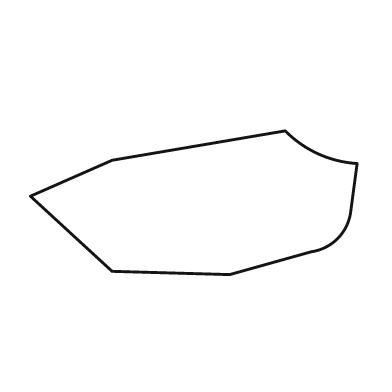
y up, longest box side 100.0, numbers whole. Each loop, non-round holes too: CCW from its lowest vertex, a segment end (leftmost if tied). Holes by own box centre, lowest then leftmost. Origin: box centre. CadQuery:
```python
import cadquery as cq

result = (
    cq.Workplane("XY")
    .moveTo(11.0, -22.0)
    .lineTo(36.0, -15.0)
    .threePointArc((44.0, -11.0), (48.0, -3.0))
    .lineTo(50.0, 12.0)
    .threePointArc((38.0, 15.0), (28.0, 22.0))
    .lineTo(-25.0, 13.0)
    .lineTo(-50.0, 2.0)
    .lineTo(-25.0, -21.0)
    .close()
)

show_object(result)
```